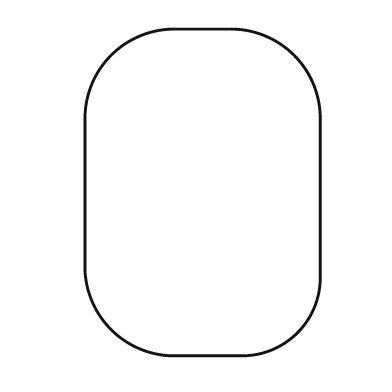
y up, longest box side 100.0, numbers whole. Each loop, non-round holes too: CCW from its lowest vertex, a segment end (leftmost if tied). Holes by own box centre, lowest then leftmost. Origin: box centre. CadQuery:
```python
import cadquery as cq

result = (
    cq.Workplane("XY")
    .moveTo(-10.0, -50.0)
    .lineTo(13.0, -50.0)
    .threePointArc((29.0, -43.0), (36.0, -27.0))
    .lineTo(36.0, 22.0)
    .threePointArc((28.0, 42.0), (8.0, 50.0))
    .lineTo(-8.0, 50.0)
    .threePointArc((-28.0, 42.0), (-36.0, 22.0))
    .lineTo(-36.0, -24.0)
    .threePointArc((-28.0, -42.0), (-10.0, -50.0))
    .close()
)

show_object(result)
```